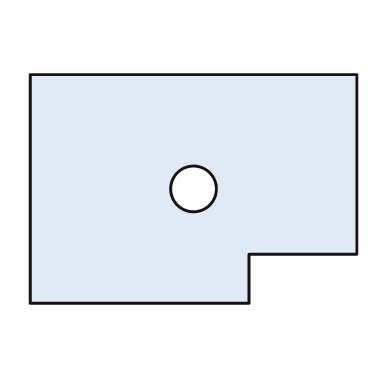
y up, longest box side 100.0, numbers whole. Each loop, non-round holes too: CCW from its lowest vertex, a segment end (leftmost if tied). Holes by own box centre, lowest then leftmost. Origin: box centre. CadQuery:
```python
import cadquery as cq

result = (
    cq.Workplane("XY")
    .moveTo(-50.0, -35.0)
    .lineTo(17.0, -35.0)
    .lineTo(17.0, -20.0)
    .lineTo(50.0, -20.0)
    .lineTo(50.0, 35.0)
    .lineTo(-50.0, 35.0)
    .close()
    .moveTo(0.0, 0.0)
    .circle(7.0)
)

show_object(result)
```